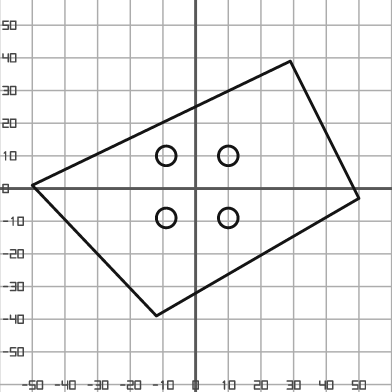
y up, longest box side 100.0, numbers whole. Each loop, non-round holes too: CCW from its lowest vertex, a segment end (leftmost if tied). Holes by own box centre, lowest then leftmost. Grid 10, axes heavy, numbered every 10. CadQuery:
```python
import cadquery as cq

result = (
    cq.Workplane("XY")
    .moveTo(-12.0, -39.0)
    .lineTo(50.0, -3.0)
    .lineTo(29.0, 39.0)
    .lineTo(-50.0, 1.0)
    .close()
    .moveTo(-9.0, -9.0)
    .circle(3.0)
    .moveTo(10.0, -9.0)
    .circle(3.0)
    .moveTo(-9.0, 10.0)
    .circle(3.0)
    .moveTo(10.0, 10.0)
    .circle(3.0)
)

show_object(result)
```